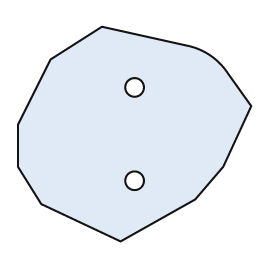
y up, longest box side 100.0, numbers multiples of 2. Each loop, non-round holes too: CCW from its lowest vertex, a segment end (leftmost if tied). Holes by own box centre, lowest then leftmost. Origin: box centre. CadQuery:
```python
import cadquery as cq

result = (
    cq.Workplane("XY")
    .moveTo(-6.0, -46.0)
    .lineTo(26.0, -28.0)
    .lineTo(38.0, -14.0)
    .lineTo(50.0, 12.0)
    .lineTo(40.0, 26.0)
    .threePointArc((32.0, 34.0), (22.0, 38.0))
    .lineTo(-14.0, 46.0)
    .lineTo(-36.0, 32.0)
    .lineTo(-50.0, 4.0)
    .lineTo(-50.0, -14.0)
    .lineTo(-40.0, -30.0)
    .close()
    .moveTo(0.0, -20.0)
    .circle(4.0)
    .moveTo(0.0, 20.0)
    .circle(4.0)
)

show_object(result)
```